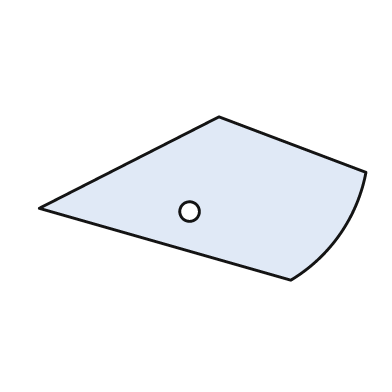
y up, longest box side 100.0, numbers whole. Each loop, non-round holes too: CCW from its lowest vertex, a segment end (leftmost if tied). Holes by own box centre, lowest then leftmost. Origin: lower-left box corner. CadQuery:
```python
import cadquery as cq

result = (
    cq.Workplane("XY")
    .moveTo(77.0, 0.0)
    .threePointArc((92.0, 14.0), (100.0, 33.0))
    .lineTo(55.0, 50.0)
    .lineTo(0.0, 22.0)
    .close()
    .moveTo(46.0, 21.0)
    .circle(3.0)
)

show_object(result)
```